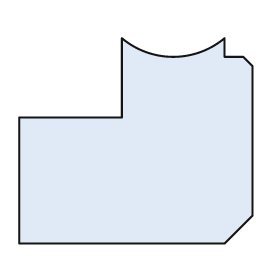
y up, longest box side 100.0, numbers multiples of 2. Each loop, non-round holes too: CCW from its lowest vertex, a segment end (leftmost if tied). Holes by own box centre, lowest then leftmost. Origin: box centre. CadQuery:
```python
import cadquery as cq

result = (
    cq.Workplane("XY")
    .moveTo(-50.0, -44.0)
    .lineTo(38.0, -44.0)
    .lineTo(50.0, -32.0)
    .lineTo(50.0, 32.0)
    .lineTo(46.0, 36.0)
    .lineTo(38.0, 36.0)
    .lineTo(38.0, 44.0)
    .threePointArc((16.0, 36.0), (-6.0, 44.0))
    .lineTo(-6.0, 10.0)
    .lineTo(-50.0, 10.0)
    .close()
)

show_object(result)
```